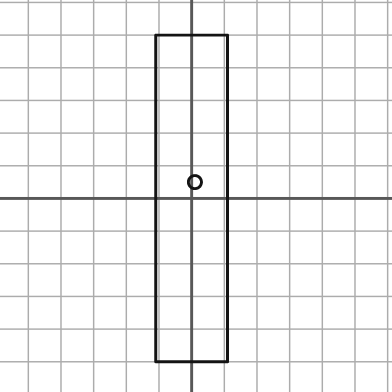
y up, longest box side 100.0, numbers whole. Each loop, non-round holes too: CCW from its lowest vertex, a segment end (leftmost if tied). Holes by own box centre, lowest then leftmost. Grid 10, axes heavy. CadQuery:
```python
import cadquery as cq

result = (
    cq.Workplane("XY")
    .moveTo(-11.0, -50.0)
    .lineTo(11.0, -50.0)
    .lineTo(11.0, 50.0)
    .lineTo(-11.0, 50.0)
    .close()
    .moveTo(1.0, 5.0)
    .circle(2.0)
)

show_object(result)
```